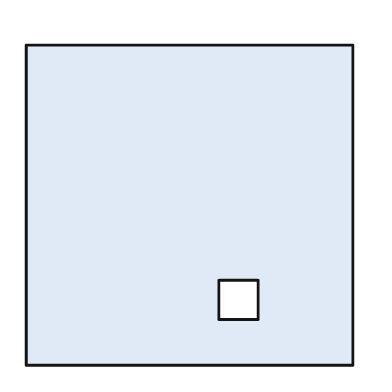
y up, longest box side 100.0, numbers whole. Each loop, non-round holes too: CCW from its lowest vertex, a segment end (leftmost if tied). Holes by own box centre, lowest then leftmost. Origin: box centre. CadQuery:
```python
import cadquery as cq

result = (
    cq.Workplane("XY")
    .moveTo(-50.0, -49.0)
    .lineTo(50.0, -49.0)
    .lineTo(50.0, 49.0)
    .lineTo(-50.0, 49.0)
    .close()
    .moveTo(9.0, -35.0)
    .lineTo(21.0, -35.0)
    .lineTo(21.0, -23.0)
    .lineTo(9.0, -23.0)
    .close()
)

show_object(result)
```